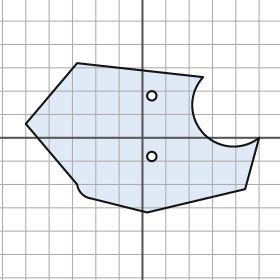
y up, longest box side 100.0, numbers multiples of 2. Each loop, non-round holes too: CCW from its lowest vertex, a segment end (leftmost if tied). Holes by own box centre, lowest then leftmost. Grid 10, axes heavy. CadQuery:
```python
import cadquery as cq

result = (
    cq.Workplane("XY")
    .moveTo(2.0, -32.0)
    .lineTo(44.0, -22.0)
    .lineTo(50.0, 0.0)
    .threePointArc((26.0, 2.0), (26.0, 26.0))
    .lineTo(-28.0, 32.0)
    .lineTo(-50.0, 6.0)
    .lineTo(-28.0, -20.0)
    .threePointArc((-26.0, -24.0), (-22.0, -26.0))
    .close()
    .moveTo(4.0, -8.0)
    .circle(2.0)
    .moveTo(4.0, 18.0)
    .circle(2.0)
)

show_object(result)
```